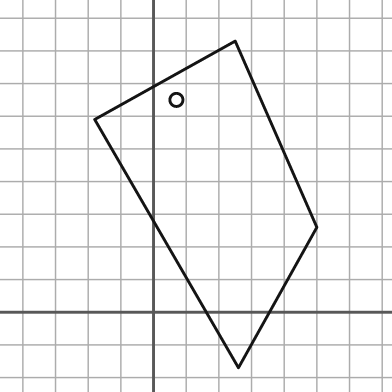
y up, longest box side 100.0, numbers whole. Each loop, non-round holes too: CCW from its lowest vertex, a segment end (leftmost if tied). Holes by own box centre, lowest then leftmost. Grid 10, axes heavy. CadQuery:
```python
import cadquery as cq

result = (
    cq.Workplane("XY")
    .moveTo(26.0, -17.0)
    .lineTo(50.0, 26.0)
    .lineTo(25.0, 83.0)
    .lineTo(-18.0, 59.0)
    .close()
    .moveTo(7.0, 65.0)
    .circle(2.0)
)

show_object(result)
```